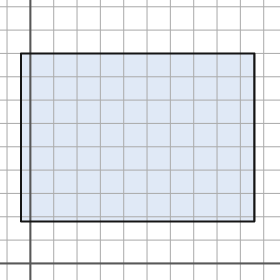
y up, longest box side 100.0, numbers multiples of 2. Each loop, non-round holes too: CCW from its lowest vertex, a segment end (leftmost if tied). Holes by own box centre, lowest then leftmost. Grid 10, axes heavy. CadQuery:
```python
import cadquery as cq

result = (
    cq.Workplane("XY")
    .moveTo(-4.0, 18.0)
    .lineTo(96.0, 18.0)
    .lineTo(96.0, 90.0)
    .lineTo(-4.0, 90.0)
    .close()
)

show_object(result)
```